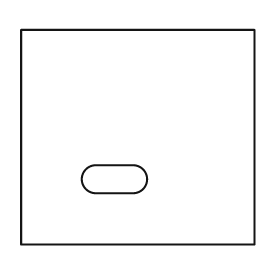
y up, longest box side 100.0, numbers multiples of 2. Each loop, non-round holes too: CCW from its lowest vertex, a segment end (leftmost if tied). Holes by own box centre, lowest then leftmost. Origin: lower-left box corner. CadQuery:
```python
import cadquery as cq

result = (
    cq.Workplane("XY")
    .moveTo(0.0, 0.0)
    .lineTo(100.0, 0.0)
    .lineTo(100.0, 92.0)
    .lineTo(0.0, 92.0)
    .close()
    .moveTo(32.0, 22.0)
    .lineTo(48.0, 22.0)
    .threePointArc((54.0, 28.0), (48.0, 34.0))
    .lineTo(32.0, 34.0)
    .threePointArc((26.0, 28.0), (32.0, 22.0))
    .close()
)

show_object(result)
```